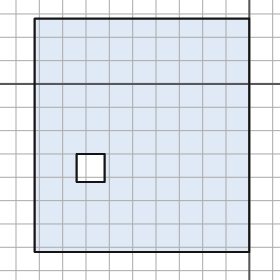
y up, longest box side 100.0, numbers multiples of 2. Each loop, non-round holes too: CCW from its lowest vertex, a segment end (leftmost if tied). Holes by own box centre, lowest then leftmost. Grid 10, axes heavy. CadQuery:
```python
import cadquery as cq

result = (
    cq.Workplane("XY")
    .moveTo(-92.0, -72.0)
    .lineTo(0.0, -72.0)
    .lineTo(0.0, 28.0)
    .lineTo(-92.0, 28.0)
    .close()
    .moveTo(-74.0, -42.0)
    .lineTo(-62.0, -42.0)
    .lineTo(-62.0, -30.0)
    .lineTo(-74.0, -30.0)
    .close()
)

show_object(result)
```